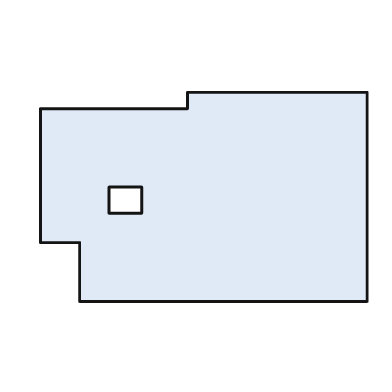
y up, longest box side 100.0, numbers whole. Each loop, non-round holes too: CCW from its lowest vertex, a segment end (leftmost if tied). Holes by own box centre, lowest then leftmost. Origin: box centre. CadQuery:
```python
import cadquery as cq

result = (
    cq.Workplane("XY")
    .moveTo(-38.0, -32.0)
    .lineTo(50.0, -32.0)
    .lineTo(50.0, 32.0)
    .lineTo(-5.0, 32.0)
    .lineTo(-5.0, 27.0)
    .lineTo(-50.0, 27.0)
    .lineTo(-50.0, -14.0)
    .lineTo(-38.0, -14.0)
    .close()
    .moveTo(-29.0, -5.0)
    .lineTo(-19.0, -5.0)
    .lineTo(-19.0, 3.0)
    .lineTo(-29.0, 3.0)
    .close()
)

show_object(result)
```